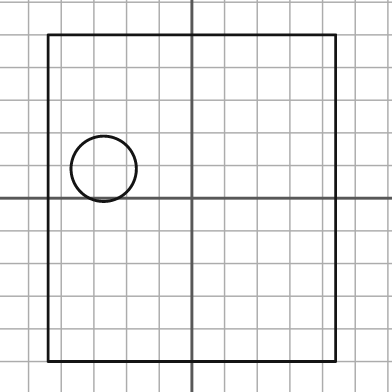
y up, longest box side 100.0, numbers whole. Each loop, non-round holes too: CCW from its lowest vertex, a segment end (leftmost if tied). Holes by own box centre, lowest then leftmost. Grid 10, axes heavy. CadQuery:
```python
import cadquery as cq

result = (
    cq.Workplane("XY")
    .moveTo(-44.0, -50.0)
    .lineTo(44.0, -50.0)
    .lineTo(44.0, 50.0)
    .lineTo(-44.0, 50.0)
    .close()
    .moveTo(-27.0, 9.0)
    .circle(10.0)
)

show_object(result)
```